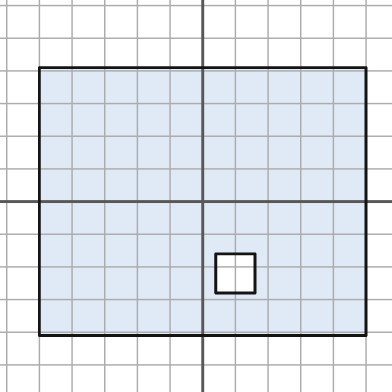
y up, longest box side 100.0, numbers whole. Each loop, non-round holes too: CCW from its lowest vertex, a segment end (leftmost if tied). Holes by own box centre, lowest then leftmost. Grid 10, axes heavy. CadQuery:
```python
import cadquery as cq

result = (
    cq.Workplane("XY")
    .moveTo(-50.0, -41.0)
    .lineTo(50.0, -41.0)
    .lineTo(50.0, 41.0)
    .lineTo(-50.0, 41.0)
    .close()
    .moveTo(4.0, -28.0)
    .lineTo(16.0, -28.0)
    .lineTo(16.0, -16.0)
    .lineTo(4.0, -16.0)
    .close()
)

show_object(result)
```